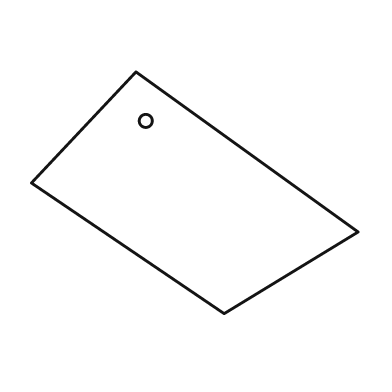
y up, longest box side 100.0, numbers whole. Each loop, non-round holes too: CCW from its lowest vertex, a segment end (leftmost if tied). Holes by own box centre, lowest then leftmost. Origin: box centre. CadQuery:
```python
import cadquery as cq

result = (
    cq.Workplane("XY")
    .moveTo(9.0, -37.0)
    .lineTo(50.0, -12.0)
    .lineTo(-18.0, 37.0)
    .lineTo(-50.0, 3.0)
    .close()
    .moveTo(-15.0, 22.0)
    .circle(2.0)
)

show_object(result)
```